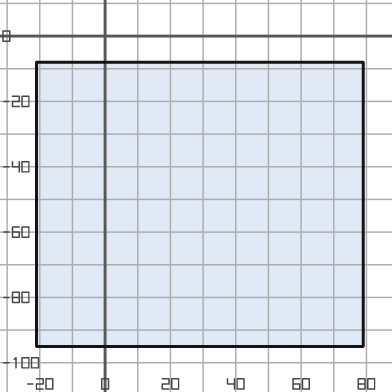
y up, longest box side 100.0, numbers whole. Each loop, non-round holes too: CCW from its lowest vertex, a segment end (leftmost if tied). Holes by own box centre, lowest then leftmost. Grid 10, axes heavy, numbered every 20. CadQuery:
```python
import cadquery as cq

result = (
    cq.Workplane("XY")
    .moveTo(-21.0, -95.0)
    .lineTo(79.0, -95.0)
    .lineTo(79.0, -8.0)
    .lineTo(-21.0, -8.0)
    .close()
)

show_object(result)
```